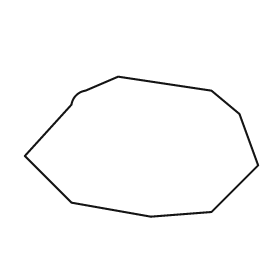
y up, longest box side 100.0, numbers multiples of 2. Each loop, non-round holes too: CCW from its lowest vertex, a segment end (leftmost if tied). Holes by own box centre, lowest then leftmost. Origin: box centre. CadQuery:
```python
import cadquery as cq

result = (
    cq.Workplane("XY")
    .moveTo(4.0, -30.0)
    .lineTo(30.0, -28.0)
    .lineTo(50.0, -8.0)
    .lineTo(42.0, 14.0)
    .lineTo(30.0, 24.0)
    .lineTo(-10.0, 30.0)
    .lineTo(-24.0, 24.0)
    .threePointArc((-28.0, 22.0), (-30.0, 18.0))
    .lineTo(-50.0, -4.0)
    .lineTo(-30.0, -24.0)
    .close()
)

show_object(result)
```